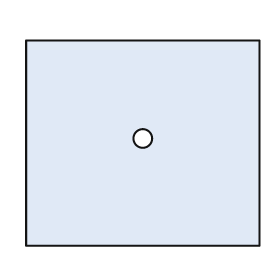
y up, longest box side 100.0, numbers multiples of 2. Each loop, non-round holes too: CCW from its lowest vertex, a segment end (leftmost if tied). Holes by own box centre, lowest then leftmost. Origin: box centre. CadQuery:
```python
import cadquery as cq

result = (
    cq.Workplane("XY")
    .moveTo(-50.0, -44.0)
    .lineTo(50.0, -44.0)
    .lineTo(50.0, 44.0)
    .lineTo(-50.0, 44.0)
    .close()
    .moveTo(0.0, 2.0)
    .circle(4.0)
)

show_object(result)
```